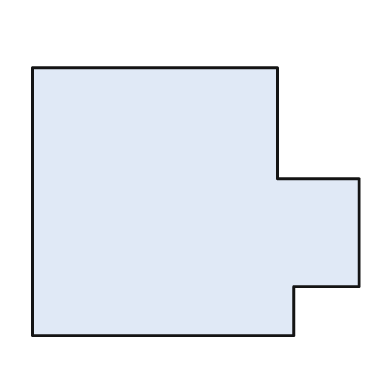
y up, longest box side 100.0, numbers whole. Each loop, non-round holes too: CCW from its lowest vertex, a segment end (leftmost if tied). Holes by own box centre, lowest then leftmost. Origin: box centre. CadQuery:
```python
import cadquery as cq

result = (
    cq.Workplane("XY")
    .moveTo(-50.0, -41.0)
    .lineTo(30.0, -41.0)
    .lineTo(30.0, -26.0)
    .lineTo(50.0, -26.0)
    .lineTo(50.0, 7.0)
    .lineTo(25.0, 7.0)
    .lineTo(25.0, 41.0)
    .lineTo(-50.0, 41.0)
    .close()
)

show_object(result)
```